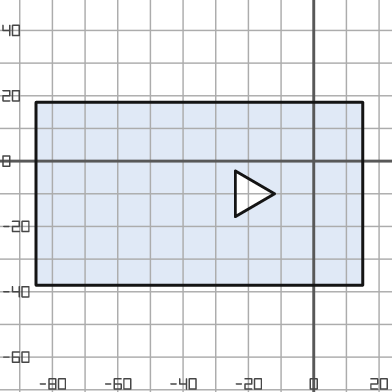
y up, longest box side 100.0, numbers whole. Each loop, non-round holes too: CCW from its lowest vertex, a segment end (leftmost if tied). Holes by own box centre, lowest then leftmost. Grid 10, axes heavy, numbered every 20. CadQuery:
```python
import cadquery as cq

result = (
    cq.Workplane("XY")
    .moveTo(-85.0, -38.0)
    .lineTo(15.0, -38.0)
    .lineTo(15.0, 18.0)
    .lineTo(-85.0, 18.0)
    .close()
    .moveTo(-24.0, -17.0)
    .lineTo(-12.0, -10.0)
    .lineTo(-24.0, -3.0)
    .close()
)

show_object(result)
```